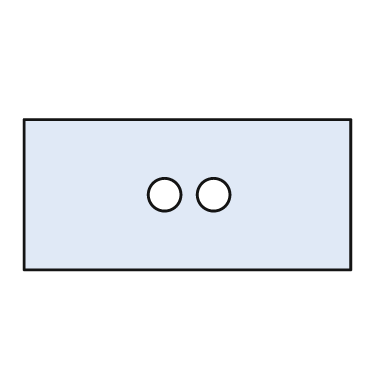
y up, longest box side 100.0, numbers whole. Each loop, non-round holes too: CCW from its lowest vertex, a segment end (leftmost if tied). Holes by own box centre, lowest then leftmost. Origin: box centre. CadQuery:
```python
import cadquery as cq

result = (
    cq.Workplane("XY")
    .moveTo(-50.0, -23.0)
    .lineTo(50.0, -23.0)
    .lineTo(50.0, 23.0)
    .lineTo(-50.0, 23.0)
    .close()
    .moveTo(-7.0, 0.0)
    .circle(5.0)
    .moveTo(8.0, 0.0)
    .circle(5.0)
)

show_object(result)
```